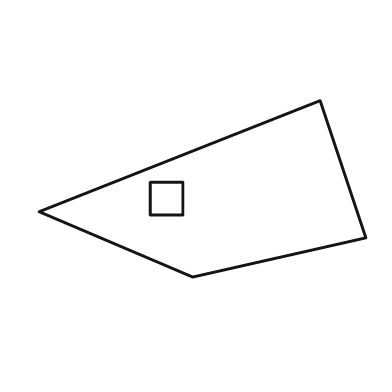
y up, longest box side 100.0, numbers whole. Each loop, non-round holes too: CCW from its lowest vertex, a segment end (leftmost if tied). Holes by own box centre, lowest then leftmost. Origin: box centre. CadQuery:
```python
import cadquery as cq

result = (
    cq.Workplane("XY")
    .moveTo(-3.0, -27.0)
    .lineTo(50.0, -15.0)
    .lineTo(36.0, 27.0)
    .lineTo(-50.0, -7.0)
    .close()
    .moveTo(-16.0, -8.0)
    .lineTo(-6.0, -8.0)
    .lineTo(-6.0, 2.0)
    .lineTo(-16.0, 2.0)
    .close()
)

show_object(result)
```